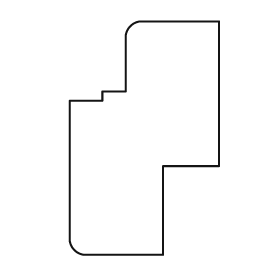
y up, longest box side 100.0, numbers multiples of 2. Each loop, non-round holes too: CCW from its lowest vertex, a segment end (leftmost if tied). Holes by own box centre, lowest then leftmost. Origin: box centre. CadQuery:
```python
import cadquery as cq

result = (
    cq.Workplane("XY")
    .moveTo(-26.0, -50.0)
    .lineTo(8.0, -50.0)
    .lineTo(8.0, -12.0)
    .lineTo(32.0, -12.0)
    .lineTo(32.0, 50.0)
    .lineTo(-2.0, 50.0)
    .threePointArc((-6.0, 48.0), (-8.0, 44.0))
    .lineTo(-8.0, 20.0)
    .lineTo(-18.0, 20.0)
    .lineTo(-18.0, 16.0)
    .lineTo(-32.0, 16.0)
    .lineTo(-32.0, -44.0)
    .threePointArc((-30.0, -48.0), (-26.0, -50.0))
    .close()
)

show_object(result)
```